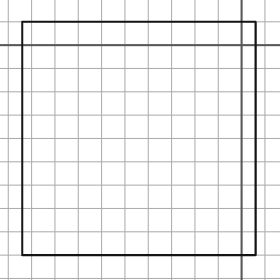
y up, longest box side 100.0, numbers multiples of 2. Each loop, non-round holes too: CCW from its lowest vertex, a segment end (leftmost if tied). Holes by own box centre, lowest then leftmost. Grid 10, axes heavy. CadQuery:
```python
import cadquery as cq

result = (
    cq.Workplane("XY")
    .moveTo(-94.0, -90.0)
    .lineTo(6.0, -90.0)
    .lineTo(6.0, 10.0)
    .lineTo(-94.0, 10.0)
    .close()
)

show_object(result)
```